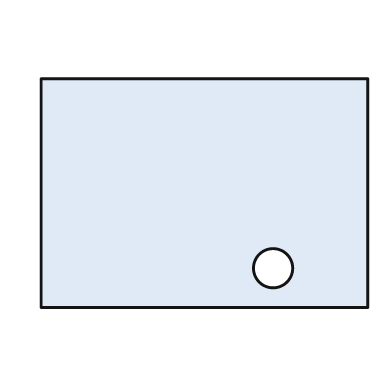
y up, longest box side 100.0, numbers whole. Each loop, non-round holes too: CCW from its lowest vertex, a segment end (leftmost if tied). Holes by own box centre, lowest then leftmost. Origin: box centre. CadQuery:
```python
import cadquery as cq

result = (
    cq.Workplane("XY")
    .moveTo(-50.0, -35.0)
    .lineTo(50.0, -35.0)
    .lineTo(50.0, 35.0)
    .lineTo(-50.0, 35.0)
    .close()
    .moveTo(21.0, -23.0)
    .circle(6.0)
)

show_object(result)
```